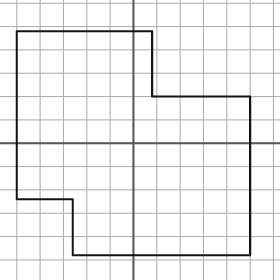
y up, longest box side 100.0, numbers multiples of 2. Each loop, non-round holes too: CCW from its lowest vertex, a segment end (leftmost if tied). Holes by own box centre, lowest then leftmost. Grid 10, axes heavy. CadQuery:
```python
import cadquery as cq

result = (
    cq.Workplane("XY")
    .moveTo(-26.0, -48.0)
    .lineTo(50.0, -48.0)
    .lineTo(50.0, 20.0)
    .lineTo(8.0, 20.0)
    .lineTo(8.0, 48.0)
    .lineTo(-50.0, 48.0)
    .lineTo(-50.0, -24.0)
    .lineTo(-26.0, -24.0)
    .close()
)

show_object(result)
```